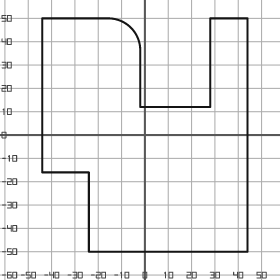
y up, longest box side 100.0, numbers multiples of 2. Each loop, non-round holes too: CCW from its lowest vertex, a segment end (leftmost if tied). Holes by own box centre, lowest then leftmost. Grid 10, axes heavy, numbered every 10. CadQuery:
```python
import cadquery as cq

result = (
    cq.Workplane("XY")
    .moveTo(-24.0, -50.0)
    .lineTo(44.0, -50.0)
    .lineTo(44.0, 50.0)
    .lineTo(28.0, 50.0)
    .lineTo(28.0, 12.0)
    .lineTo(-2.0, 12.0)
    .lineTo(-2.0, 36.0)
    .threePointArc((-6.0, 46.0), (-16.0, 50.0))
    .lineTo(-44.0, 50.0)
    .lineTo(-44.0, -16.0)
    .lineTo(-24.0, -16.0)
    .close()
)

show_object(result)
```